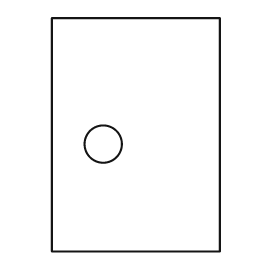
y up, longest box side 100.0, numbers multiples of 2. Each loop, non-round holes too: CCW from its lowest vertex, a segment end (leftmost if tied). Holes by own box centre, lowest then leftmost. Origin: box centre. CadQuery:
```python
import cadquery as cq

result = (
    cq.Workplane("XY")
    .moveTo(-36.0, -50.0)
    .lineTo(36.0, -50.0)
    .lineTo(36.0, 50.0)
    .lineTo(-36.0, 50.0)
    .close()
    .moveTo(-14.0, -4.0)
    .circle(8.0)
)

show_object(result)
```